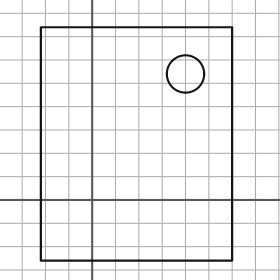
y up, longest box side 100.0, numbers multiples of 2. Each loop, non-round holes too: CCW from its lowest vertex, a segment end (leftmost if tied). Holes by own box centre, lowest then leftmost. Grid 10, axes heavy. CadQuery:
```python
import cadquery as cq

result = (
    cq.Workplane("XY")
    .moveTo(-22.0, -26.0)
    .lineTo(60.0, -26.0)
    .lineTo(60.0, 74.0)
    .lineTo(-22.0, 74.0)
    .close()
    .moveTo(40.0, 54.0)
    .circle(8.0)
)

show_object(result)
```